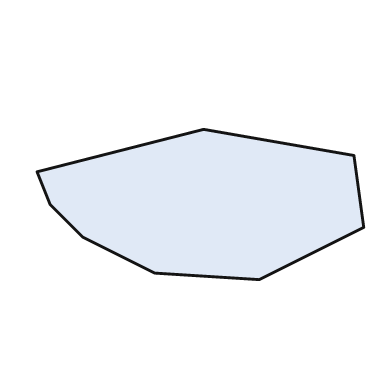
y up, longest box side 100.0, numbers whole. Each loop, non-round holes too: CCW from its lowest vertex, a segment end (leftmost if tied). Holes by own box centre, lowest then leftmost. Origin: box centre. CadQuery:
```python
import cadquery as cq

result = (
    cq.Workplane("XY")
    .moveTo(18.0, -23.0)
    .lineTo(50.0, -7.0)
    .lineTo(47.0, 15.0)
    .lineTo(1.0, 23.0)
    .lineTo(-50.0, 10.0)
    .lineTo(-46.0, 0.0)
    .lineTo(-36.0, -10.0)
    .lineTo(-14.0, -21.0)
    .close()
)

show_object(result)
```